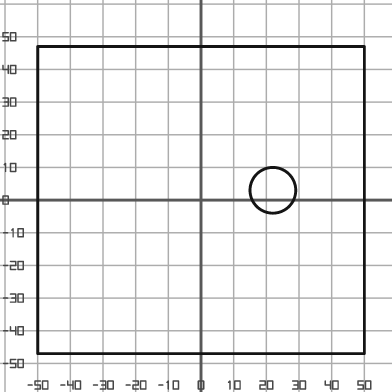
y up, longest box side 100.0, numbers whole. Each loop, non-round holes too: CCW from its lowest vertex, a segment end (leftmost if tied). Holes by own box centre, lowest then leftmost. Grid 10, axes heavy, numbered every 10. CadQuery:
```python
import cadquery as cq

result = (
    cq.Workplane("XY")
    .moveTo(-50.0, -47.0)
    .lineTo(50.0, -47.0)
    .lineTo(50.0, 47.0)
    .lineTo(-50.0, 47.0)
    .close()
    .moveTo(22.0, 3.0)
    .circle(7.0)
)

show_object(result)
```